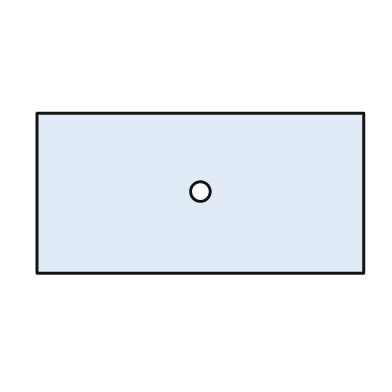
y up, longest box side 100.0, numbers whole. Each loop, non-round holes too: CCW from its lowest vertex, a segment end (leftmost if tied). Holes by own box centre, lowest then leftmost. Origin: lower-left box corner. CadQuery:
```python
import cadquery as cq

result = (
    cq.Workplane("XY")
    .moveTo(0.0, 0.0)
    .lineTo(100.0, 0.0)
    .lineTo(100.0, 49.0)
    .lineTo(0.0, 49.0)
    .close()
    .moveTo(50.0, 25.0)
    .circle(3.0)
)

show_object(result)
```